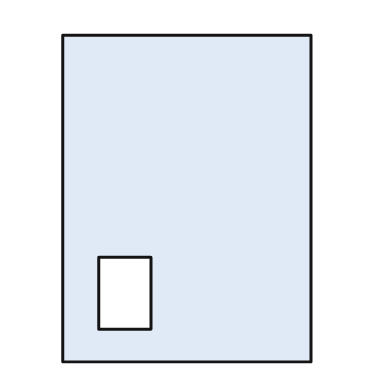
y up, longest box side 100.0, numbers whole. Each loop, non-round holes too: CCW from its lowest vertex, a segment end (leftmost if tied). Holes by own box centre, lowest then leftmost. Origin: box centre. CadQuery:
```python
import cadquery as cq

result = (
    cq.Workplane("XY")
    .moveTo(-38.0, -50.0)
    .lineTo(38.0, -50.0)
    .lineTo(38.0, 50.0)
    .lineTo(-38.0, 50.0)
    .close()
    .moveTo(-27.0, -40.0)
    .lineTo(-11.0, -40.0)
    .lineTo(-11.0, -18.0)
    .lineTo(-27.0, -18.0)
    .close()
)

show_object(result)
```